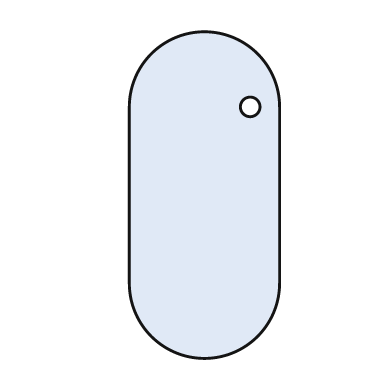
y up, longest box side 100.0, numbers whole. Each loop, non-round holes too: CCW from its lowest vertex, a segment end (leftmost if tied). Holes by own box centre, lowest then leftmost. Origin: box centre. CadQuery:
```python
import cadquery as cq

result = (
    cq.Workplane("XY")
    .moveTo(-23.0, -27.0)
    .threePointArc((0.0, -50.0), (23.0, -27.0))
    .lineTo(23.0, 27.0)
    .threePointArc((0.0, 50.0), (-23.0, 27.0))
    .close()
    .moveTo(14.0, 27.0)
    .circle(3.0)
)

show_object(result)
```